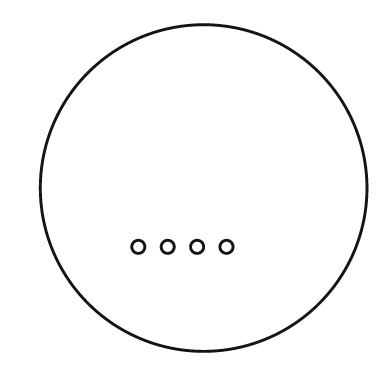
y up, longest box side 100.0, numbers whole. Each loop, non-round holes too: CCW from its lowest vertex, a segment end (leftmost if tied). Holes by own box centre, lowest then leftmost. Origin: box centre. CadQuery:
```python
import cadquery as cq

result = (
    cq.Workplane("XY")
    .moveTo(0.0, 0.0)
    .circle(50.0)
    .moveTo(-20.0, -18.0)
    .circle(2.0)
    .moveTo(-11.0, -18.0)
    .circle(2.0)
    .moveTo(-2.0, -18.0)
    .circle(2.0)
    .moveTo(7.0, -18.0)
    .circle(2.0)
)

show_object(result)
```